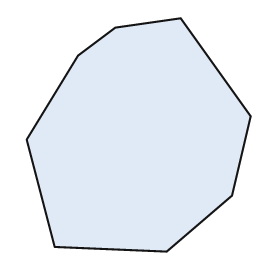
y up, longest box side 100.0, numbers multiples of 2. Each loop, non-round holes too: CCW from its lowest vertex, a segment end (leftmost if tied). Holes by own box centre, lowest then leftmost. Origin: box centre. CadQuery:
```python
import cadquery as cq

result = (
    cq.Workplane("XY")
    .moveTo(12.0, -50.0)
    .lineTo(40.0, -26.0)
    .lineTo(48.0, 8.0)
    .lineTo(18.0, 50.0)
    .lineTo(-10.0, 46.0)
    .lineTo(-26.0, 34.0)
    .lineTo(-48.0, -2.0)
    .lineTo(-36.0, -48.0)
    .close()
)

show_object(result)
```